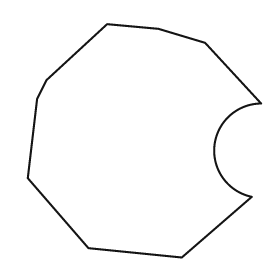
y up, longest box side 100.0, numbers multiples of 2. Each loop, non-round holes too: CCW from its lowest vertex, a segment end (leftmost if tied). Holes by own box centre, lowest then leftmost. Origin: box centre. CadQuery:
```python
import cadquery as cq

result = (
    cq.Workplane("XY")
    .moveTo(16.0, -50.0)
    .lineTo(46.0, -24.0)
    .threePointArc((30.0, -2.0), (50.0, 16.0))
    .lineTo(26.0, 42.0)
    .lineTo(6.0, 48.0)
    .lineTo(-16.0, 50.0)
    .lineTo(-42.0, 26.0)
    .lineTo(-46.0, 18.0)
    .lineTo(-50.0, -16.0)
    .lineTo(-24.0, -46.0)
    .close()
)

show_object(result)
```